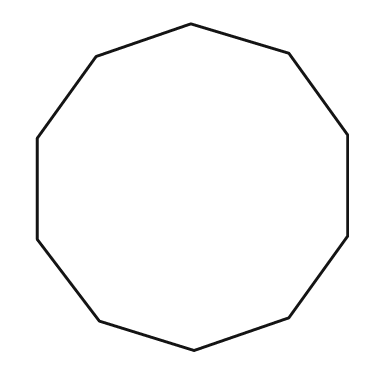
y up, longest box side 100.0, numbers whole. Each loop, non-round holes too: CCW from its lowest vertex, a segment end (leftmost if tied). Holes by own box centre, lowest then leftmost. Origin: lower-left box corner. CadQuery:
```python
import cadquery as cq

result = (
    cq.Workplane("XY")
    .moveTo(48.0, 0.0)
    .lineTo(77.0, 10.0)
    .lineTo(95.0, 35.0)
    .lineTo(95.0, 66.0)
    .lineTo(77.0, 91.0)
    .lineTo(47.0, 100.0)
    .lineTo(18.0, 90.0)
    .lineTo(0.0, 65.0)
    .lineTo(0.0, 34.0)
    .lineTo(19.0, 9.0)
    .close()
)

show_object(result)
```